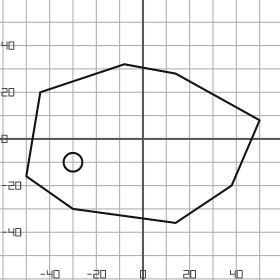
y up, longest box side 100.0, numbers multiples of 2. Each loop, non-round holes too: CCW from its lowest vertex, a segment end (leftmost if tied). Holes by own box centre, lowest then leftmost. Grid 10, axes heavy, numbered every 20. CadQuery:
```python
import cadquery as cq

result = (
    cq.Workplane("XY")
    .moveTo(14.0, -36.0)
    .lineTo(38.0, -20.0)
    .lineTo(50.0, 8.0)
    .lineTo(14.0, 28.0)
    .lineTo(-8.0, 32.0)
    .lineTo(-44.0, 20.0)
    .lineTo(-50.0, -16.0)
    .lineTo(-30.0, -30.0)
    .close()
    .moveTo(-30.0, -10.0)
    .circle(4.0)
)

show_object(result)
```